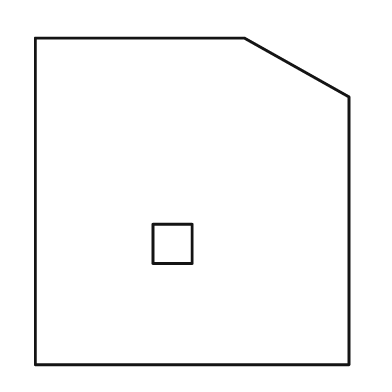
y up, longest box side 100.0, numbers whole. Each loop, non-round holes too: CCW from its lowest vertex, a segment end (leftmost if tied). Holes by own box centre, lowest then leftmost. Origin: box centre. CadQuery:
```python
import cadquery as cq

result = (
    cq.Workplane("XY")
    .moveTo(-48.0, -50.0)
    .lineTo(48.0, -50.0)
    .lineTo(48.0, 32.0)
    .lineTo(16.0, 50.0)
    .lineTo(-48.0, 50.0)
    .close()
    .moveTo(-12.0, -19.0)
    .lineTo(0.0, -19.0)
    .lineTo(0.0, -7.0)
    .lineTo(-12.0, -7.0)
    .close()
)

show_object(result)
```